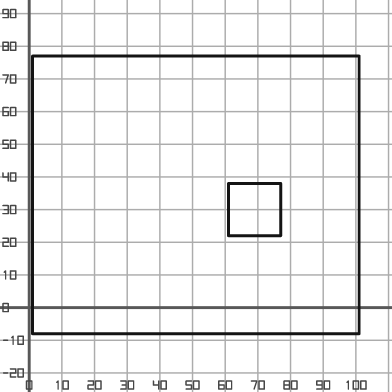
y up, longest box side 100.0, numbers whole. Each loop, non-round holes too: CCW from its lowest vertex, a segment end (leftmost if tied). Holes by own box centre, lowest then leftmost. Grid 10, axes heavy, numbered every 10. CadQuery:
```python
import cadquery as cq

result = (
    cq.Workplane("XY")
    .moveTo(1.0, -8.0)
    .lineTo(101.0, -8.0)
    .lineTo(101.0, 77.0)
    .lineTo(1.0, 77.0)
    .close()
    .moveTo(61.0, 22.0)
    .lineTo(77.0, 22.0)
    .lineTo(77.0, 38.0)
    .lineTo(61.0, 38.0)
    .close()
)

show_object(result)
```